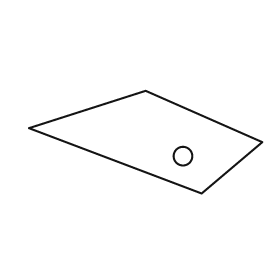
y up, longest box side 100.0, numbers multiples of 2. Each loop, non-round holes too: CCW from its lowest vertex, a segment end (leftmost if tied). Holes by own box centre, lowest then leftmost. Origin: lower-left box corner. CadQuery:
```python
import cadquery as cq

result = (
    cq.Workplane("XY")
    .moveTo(74.0, 0.0)
    .lineTo(100.0, 22.0)
    .lineTo(50.0, 44.0)
    .lineTo(0.0, 28.0)
    .close()
    .moveTo(66.0, 16.0)
    .circle(4.0)
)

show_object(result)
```